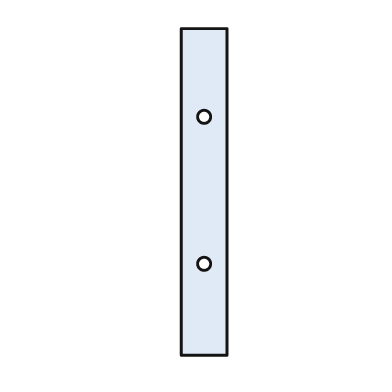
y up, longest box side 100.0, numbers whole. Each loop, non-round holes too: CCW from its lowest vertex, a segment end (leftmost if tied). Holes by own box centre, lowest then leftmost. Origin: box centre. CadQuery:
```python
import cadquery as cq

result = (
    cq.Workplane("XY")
    .moveTo(-7.0, -50.0)
    .lineTo(7.0, -50.0)
    .lineTo(7.0, 50.0)
    .lineTo(-7.0, 50.0)
    .close()
    .moveTo(0.0, -22.0)
    .circle(2.0)
    .moveTo(0.0, 23.0)
    .circle(2.0)
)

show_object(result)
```